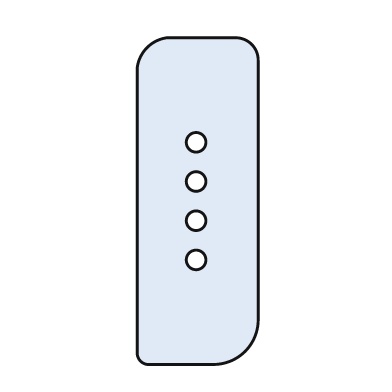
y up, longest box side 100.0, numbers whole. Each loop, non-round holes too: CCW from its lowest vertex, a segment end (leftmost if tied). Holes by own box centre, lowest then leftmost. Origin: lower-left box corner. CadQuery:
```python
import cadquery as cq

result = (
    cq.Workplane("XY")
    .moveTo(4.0, 0.0)
    .lineTo(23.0, 0.0)
    .threePointArc((33.0, 4.0), (37.0, 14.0))
    .lineTo(37.0, 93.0)
    .threePointArc((35.0, 98.0), (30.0, 100.0))
    .lineTo(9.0, 100.0)
    .threePointArc((3.0, 97.0), (0.0, 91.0))
    .lineTo(0.0, 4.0)
    .threePointArc((1.0, 1.0), (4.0, 0.0))
    .close()
    .moveTo(18.0, 32.0)
    .circle(3.0)
    .moveTo(18.0, 44.0)
    .circle(3.0)
    .moveTo(18.0, 56.0)
    .circle(3.0)
    .moveTo(18.0, 68.0)
    .circle(3.0)
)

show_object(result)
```